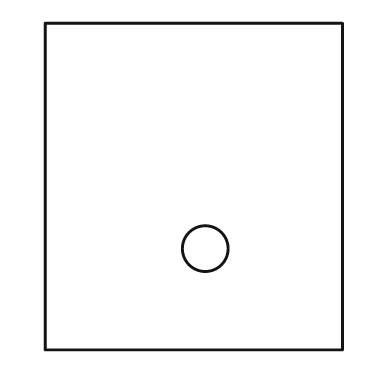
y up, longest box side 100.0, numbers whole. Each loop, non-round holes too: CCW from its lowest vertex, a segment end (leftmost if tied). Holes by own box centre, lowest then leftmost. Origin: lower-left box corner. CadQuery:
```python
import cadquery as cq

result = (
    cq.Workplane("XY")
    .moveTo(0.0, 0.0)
    .lineTo(91.0, 0.0)
    .lineTo(91.0, 100.0)
    .lineTo(0.0, 100.0)
    .close()
    .moveTo(49.0, 31.0)
    .circle(7.0)
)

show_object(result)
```